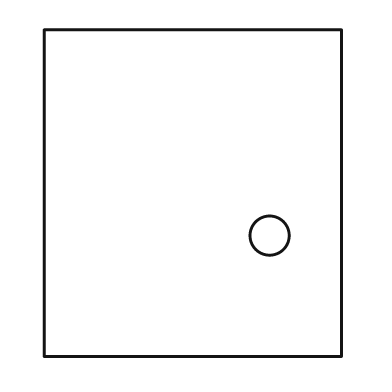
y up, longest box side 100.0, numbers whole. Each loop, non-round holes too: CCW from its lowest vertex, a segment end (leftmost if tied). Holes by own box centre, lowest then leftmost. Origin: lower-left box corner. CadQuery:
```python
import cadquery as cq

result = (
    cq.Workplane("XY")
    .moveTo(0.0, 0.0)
    .lineTo(91.0, 0.0)
    .lineTo(91.0, 100.0)
    .lineTo(0.0, 100.0)
    .close()
    .moveTo(69.0, 37.0)
    .circle(6.0)
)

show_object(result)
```